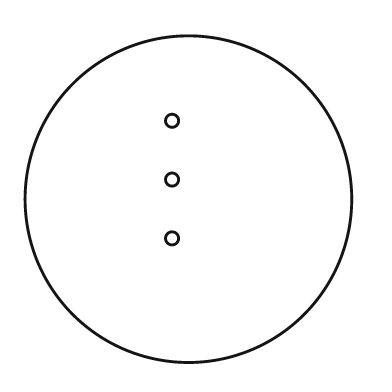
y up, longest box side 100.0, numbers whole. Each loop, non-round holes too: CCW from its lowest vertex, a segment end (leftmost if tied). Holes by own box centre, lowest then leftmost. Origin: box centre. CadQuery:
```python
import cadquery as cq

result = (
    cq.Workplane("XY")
    .moveTo(0.0, 0.0)
    .circle(50.0)
    .moveTo(-5.0, -12.0)
    .circle(2.0)
    .moveTo(-5.0, 6.0)
    .circle(2.0)
    .moveTo(-5.0, 24.0)
    .circle(2.0)
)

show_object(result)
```